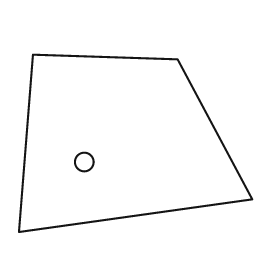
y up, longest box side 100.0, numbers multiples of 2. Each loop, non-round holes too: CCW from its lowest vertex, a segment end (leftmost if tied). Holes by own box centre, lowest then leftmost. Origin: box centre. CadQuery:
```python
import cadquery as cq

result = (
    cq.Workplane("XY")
    .moveTo(-50.0, -38.0)
    .lineTo(50.0, -24.0)
    .lineTo(18.0, 36.0)
    .lineTo(-44.0, 38.0)
    .close()
    .moveTo(-22.0, -8.0)
    .circle(4.0)
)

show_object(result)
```